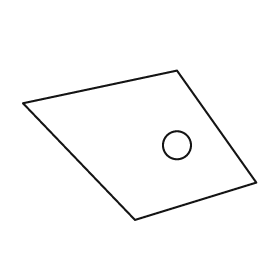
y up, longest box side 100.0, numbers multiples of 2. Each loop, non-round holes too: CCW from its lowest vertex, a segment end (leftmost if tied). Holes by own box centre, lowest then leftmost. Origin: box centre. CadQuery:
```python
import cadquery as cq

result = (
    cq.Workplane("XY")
    .moveTo(-2.0, -32.0)
    .lineTo(50.0, -16.0)
    .lineTo(16.0, 32.0)
    .lineTo(-50.0, 18.0)
    .close()
    .moveTo(16.0, 0.0)
    .circle(6.0)
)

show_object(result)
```